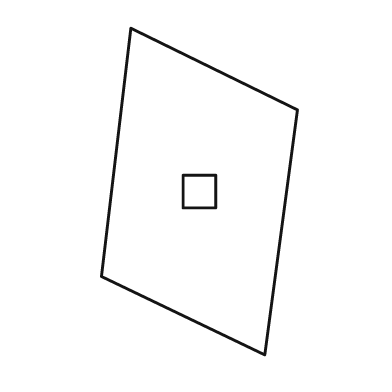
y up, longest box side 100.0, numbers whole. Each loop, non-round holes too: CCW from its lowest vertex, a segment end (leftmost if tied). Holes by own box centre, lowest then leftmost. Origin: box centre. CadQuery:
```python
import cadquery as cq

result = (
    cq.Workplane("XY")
    .moveTo(20.0, -50.0)
    .lineTo(30.0, 25.0)
    .lineTo(-21.0, 50.0)
    .lineTo(-30.0, -26.0)
    .close()
    .moveTo(-5.0, -5.0)
    .lineTo(5.0, -5.0)
    .lineTo(5.0, 5.0)
    .lineTo(-5.0, 5.0)
    .close()
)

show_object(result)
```